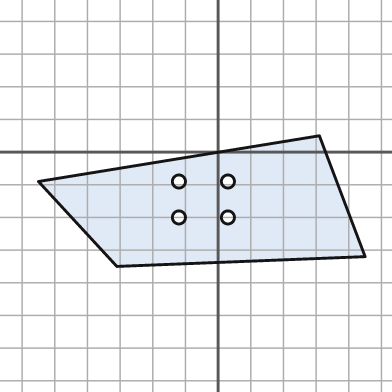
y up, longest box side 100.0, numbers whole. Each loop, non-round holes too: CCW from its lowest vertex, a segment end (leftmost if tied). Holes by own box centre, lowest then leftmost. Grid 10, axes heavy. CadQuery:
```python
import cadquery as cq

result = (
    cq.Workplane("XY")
    .moveTo(-31.0, -35.0)
    .lineTo(45.0, -32.0)
    .lineTo(31.0, 5.0)
    .lineTo(-55.0, -9.0)
    .close()
    .moveTo(-12.0, -20.0)
    .circle(2.0)
    .moveTo(3.0, -20.0)
    .circle(2.0)
    .moveTo(-12.0, -9.0)
    .circle(2.0)
    .moveTo(3.0, -9.0)
    .circle(2.0)
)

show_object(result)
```